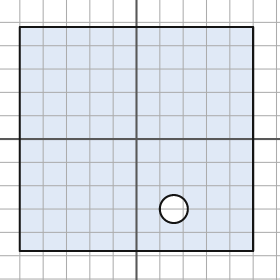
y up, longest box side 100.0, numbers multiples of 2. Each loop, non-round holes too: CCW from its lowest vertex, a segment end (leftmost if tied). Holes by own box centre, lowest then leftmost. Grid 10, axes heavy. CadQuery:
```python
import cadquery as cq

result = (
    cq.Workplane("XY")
    .moveTo(-50.0, -48.0)
    .lineTo(50.0, -48.0)
    .lineTo(50.0, 48.0)
    .lineTo(-50.0, 48.0)
    .close()
    .moveTo(16.0, -30.0)
    .circle(6.0)
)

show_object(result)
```